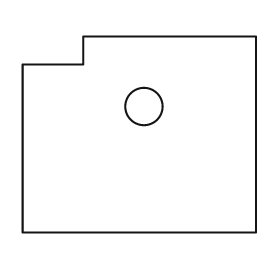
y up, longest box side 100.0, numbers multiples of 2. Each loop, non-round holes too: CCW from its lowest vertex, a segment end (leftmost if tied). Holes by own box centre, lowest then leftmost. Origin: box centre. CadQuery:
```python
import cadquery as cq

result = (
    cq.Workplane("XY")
    .moveTo(-50.0, -42.0)
    .lineTo(50.0, -42.0)
    .lineTo(50.0, 42.0)
    .lineTo(-24.0, 42.0)
    .lineTo(-24.0, 30.0)
    .lineTo(-50.0, 30.0)
    .close()
    .moveTo(2.0, 12.0)
    .circle(8.0)
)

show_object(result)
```